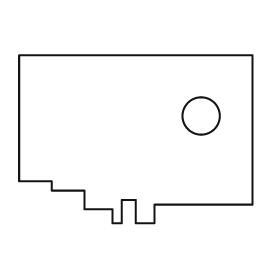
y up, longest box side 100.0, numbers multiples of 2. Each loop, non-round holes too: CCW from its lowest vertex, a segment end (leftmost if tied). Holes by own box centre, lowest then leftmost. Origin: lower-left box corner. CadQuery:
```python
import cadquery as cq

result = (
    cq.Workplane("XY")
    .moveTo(40.0, 0.0)
    .lineTo(44.0, 0.0)
    .lineTo(44.0, 10.0)
    .lineTo(50.0, 10.0)
    .lineTo(50.0, 0.0)
    .lineTo(58.0, 0.0)
    .lineTo(58.0, 8.0)
    .lineTo(100.0, 8.0)
    .lineTo(100.0, 72.0)
    .lineTo(0.0, 72.0)
    .lineTo(0.0, 18.0)
    .lineTo(14.0, 18.0)
    .lineTo(14.0, 14.0)
    .lineTo(28.0, 14.0)
    .lineTo(28.0, 6.0)
    .lineTo(40.0, 6.0)
    .close()
    .moveTo(78.0, 46.0)
    .circle(8.0)
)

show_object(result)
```